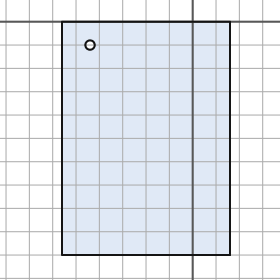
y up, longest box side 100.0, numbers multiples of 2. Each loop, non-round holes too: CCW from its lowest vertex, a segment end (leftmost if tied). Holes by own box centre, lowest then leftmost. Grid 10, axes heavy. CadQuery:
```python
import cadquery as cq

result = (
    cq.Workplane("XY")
    .moveTo(-56.0, -100.0)
    .lineTo(16.0, -100.0)
    .lineTo(16.0, 0.0)
    .lineTo(-56.0, 0.0)
    .close()
    .moveTo(-44.0, -10.0)
    .circle(2.0)
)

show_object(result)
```